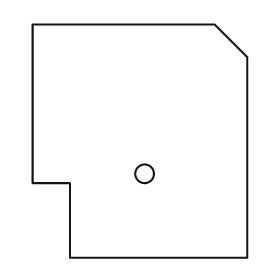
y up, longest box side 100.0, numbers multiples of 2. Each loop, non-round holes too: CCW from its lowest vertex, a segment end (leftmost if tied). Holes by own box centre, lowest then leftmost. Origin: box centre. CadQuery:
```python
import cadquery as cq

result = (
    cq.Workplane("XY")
    .moveTo(-30.0, -50.0)
    .lineTo(46.0, -50.0)
    .lineTo(46.0, 36.0)
    .lineTo(32.0, 50.0)
    .lineTo(-46.0, 50.0)
    .lineTo(-46.0, -18.0)
    .lineTo(-30.0, -18.0)
    .close()
    .moveTo(2.0, -14.0)
    .circle(4.0)
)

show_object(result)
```